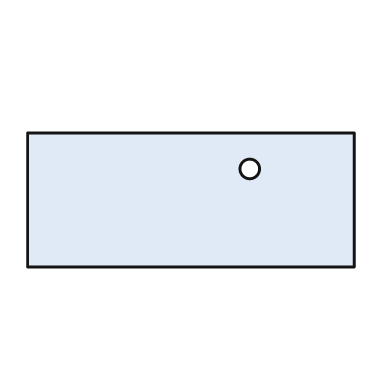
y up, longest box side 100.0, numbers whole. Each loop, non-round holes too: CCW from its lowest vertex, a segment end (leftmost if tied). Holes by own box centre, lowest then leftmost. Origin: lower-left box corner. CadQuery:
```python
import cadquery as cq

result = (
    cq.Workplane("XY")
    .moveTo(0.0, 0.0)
    .lineTo(100.0, 0.0)
    .lineTo(100.0, 41.0)
    .lineTo(0.0, 41.0)
    .close()
    .moveTo(68.0, 30.0)
    .circle(3.0)
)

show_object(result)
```